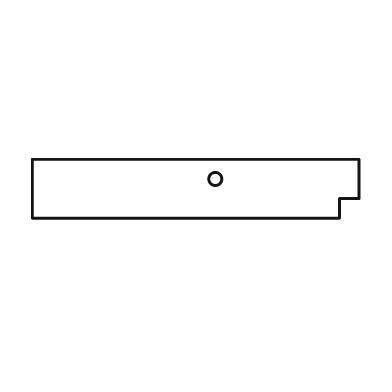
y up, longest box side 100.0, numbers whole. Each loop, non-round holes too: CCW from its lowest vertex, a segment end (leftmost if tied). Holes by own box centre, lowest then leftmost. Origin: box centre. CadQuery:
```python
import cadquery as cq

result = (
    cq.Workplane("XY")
    .moveTo(-50.0, -9.0)
    .lineTo(44.0, -9.0)
    .lineTo(44.0, -3.0)
    .lineTo(50.0, -3.0)
    .lineTo(50.0, 9.0)
    .lineTo(-50.0, 9.0)
    .close()
    .moveTo(6.0, 3.0)
    .circle(2.0)
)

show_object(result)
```